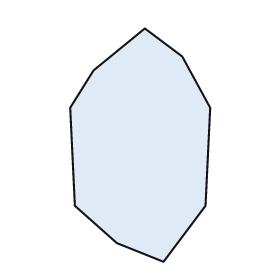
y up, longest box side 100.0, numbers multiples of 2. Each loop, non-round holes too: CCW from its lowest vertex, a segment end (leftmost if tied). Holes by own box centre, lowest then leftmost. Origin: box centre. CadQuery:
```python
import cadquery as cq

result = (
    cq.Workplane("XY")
    .moveTo(10.0, -50.0)
    .lineTo(28.0, -26.0)
    .lineTo(30.0, 16.0)
    .lineTo(18.0, 38.0)
    .lineTo(2.0, 50.0)
    .lineTo(-20.0, 32.0)
    .lineTo(-30.0, 16.0)
    .lineTo(-28.0, -26.0)
    .lineTo(-10.0, -42.0)
    .close()
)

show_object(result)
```